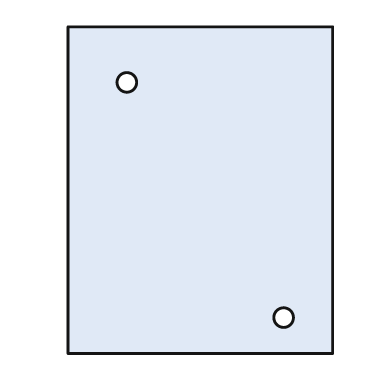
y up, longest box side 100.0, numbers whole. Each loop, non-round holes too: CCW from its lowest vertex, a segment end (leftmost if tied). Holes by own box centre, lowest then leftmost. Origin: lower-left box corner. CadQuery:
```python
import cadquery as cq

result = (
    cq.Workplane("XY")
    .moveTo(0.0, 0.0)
    .lineTo(81.0, 0.0)
    .lineTo(81.0, 100.0)
    .lineTo(0.0, 100.0)
    .close()
    .moveTo(66.0, 11.0)
    .circle(3.0)
    .moveTo(18.0, 83.0)
    .circle(3.0)
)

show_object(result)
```